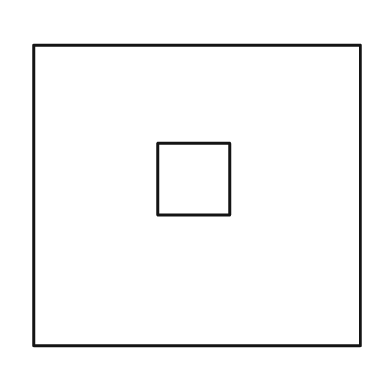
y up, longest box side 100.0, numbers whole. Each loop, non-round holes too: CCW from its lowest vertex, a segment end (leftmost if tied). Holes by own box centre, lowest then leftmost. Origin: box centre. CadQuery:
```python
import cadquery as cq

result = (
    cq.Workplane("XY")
    .moveTo(-50.0, -46.0)
    .lineTo(50.0, -46.0)
    .lineTo(50.0, 46.0)
    .lineTo(-50.0, 46.0)
    .close()
    .moveTo(-12.0, -6.0)
    .lineTo(10.0, -6.0)
    .lineTo(10.0, 16.0)
    .lineTo(-12.0, 16.0)
    .close()
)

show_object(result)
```